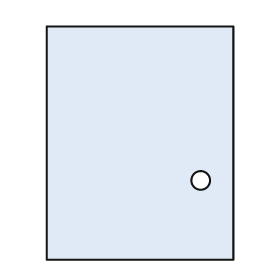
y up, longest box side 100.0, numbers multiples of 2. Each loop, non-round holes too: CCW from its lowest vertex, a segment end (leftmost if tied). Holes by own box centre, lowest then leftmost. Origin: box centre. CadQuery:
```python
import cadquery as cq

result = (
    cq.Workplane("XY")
    .moveTo(-40.0, -50.0)
    .lineTo(40.0, -50.0)
    .lineTo(40.0, 50.0)
    .lineTo(-40.0, 50.0)
    .close()
    .moveTo(26.0, -16.0)
    .circle(4.0)
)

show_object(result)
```